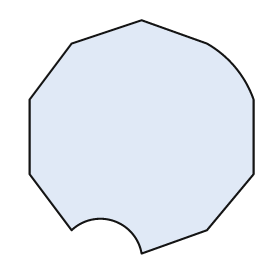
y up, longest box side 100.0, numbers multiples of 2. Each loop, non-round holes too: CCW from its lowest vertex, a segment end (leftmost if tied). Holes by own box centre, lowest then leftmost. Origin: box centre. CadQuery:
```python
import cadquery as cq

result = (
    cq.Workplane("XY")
    .moveTo(0.0, -50.0)
    .lineTo(28.0, -40.0)
    .lineTo(48.0, -16.0)
    .lineTo(48.0, 16.0)
    .threePointArc((40.0, 30.0), (28.0, 40.0))
    .lineTo(0.0, 50.0)
    .lineTo(-30.0, 40.0)
    .lineTo(-48.0, 16.0)
    .lineTo(-48.0, -16.0)
    .lineTo(-30.0, -40.0)
    .threePointArc((-12.0, -36.0), (0.0, -50.0))
    .close()
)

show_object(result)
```